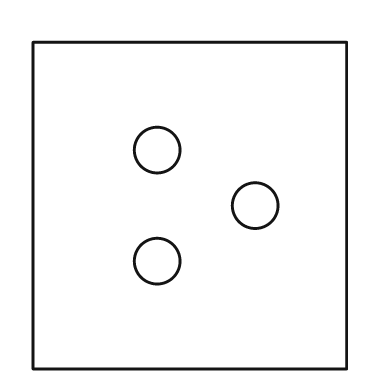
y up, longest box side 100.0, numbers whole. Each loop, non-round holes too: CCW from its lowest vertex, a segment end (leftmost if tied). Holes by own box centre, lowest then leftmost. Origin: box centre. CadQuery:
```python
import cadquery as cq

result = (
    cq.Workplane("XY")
    .moveTo(-48.0, -50.0)
    .lineTo(48.0, -50.0)
    .lineTo(48.0, 50.0)
    .lineTo(-48.0, 50.0)
    .close()
    .moveTo(-10.0, -17.0)
    .circle(7.0)
    .moveTo(20.0, 0.0)
    .circle(7.0)
    .moveTo(-10.0, 17.0)
    .circle(7.0)
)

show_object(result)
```